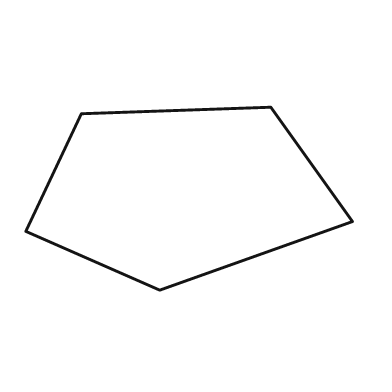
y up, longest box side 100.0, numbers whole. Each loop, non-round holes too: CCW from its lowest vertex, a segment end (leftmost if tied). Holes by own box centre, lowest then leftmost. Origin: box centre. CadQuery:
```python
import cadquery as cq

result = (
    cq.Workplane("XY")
    .moveTo(-9.0, -28.0)
    .lineTo(50.0, -7.0)
    .lineTo(25.0, 28.0)
    .lineTo(-33.0, 26.0)
    .lineTo(-50.0, -10.0)
    .close()
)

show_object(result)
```